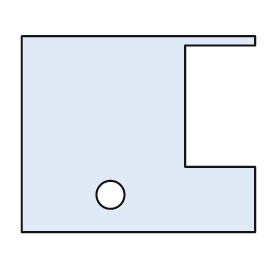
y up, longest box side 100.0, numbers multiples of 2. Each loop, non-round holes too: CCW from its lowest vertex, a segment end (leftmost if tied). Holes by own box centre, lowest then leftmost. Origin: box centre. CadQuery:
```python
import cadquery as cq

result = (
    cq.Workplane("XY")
    .moveTo(-50.0, -42.0)
    .lineTo(50.0, -42.0)
    .lineTo(50.0, -14.0)
    .lineTo(20.0, -14.0)
    .lineTo(20.0, 38.0)
    .lineTo(50.0, 38.0)
    .lineTo(50.0, 42.0)
    .lineTo(-50.0, 42.0)
    .close()
    .moveTo(-12.0, -26.0)
    .circle(6.0)
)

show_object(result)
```